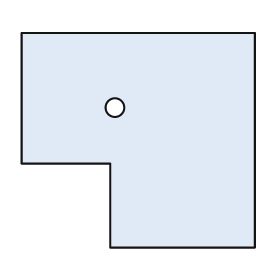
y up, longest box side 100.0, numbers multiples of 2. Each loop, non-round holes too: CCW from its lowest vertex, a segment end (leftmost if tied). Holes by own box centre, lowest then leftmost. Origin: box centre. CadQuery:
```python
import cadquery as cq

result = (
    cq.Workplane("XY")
    .moveTo(-12.0, -46.0)
    .lineTo(50.0, -46.0)
    .lineTo(50.0, 46.0)
    .lineTo(-50.0, 46.0)
    .lineTo(-50.0, -10.0)
    .lineTo(-12.0, -10.0)
    .close()
    .moveTo(-10.0, 14.0)
    .circle(4.0)
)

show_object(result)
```